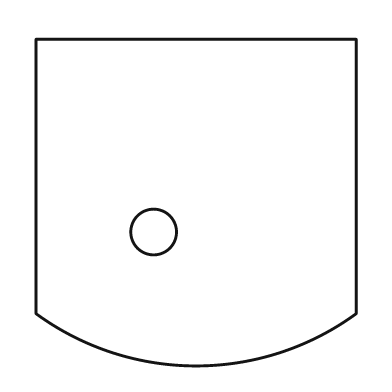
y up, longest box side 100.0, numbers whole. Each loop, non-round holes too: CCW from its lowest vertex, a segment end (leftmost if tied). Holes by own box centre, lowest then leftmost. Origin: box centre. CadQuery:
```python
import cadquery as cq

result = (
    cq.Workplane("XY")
    .moveTo(-49.0, -34.0)
    .threePointArc((0.0, -50.0), (49.0, -34.0))
    .lineTo(49.0, 50.0)
    .lineTo(-49.0, 50.0)
    .close()
    .moveTo(-13.0, -9.0)
    .circle(7.0)
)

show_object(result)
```